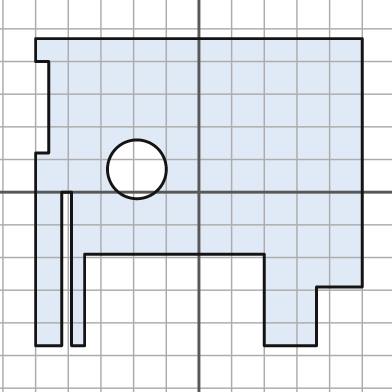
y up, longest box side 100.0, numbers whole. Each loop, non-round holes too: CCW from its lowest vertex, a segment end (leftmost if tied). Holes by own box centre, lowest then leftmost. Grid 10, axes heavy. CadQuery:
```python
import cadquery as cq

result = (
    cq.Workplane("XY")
    .moveTo(-50.0, -47.0)
    .lineTo(-42.0, -47.0)
    .lineTo(-42.0, 0.0)
    .lineTo(-39.0, 0.0)
    .lineTo(-39.0, -47.0)
    .lineTo(-35.0, -47.0)
    .lineTo(-35.0, -19.0)
    .lineTo(20.0, -19.0)
    .lineTo(20.0, -47.0)
    .lineTo(36.0, -47.0)
    .lineTo(36.0, -29.0)
    .lineTo(50.0, -29.0)
    .lineTo(50.0, 47.0)
    .lineTo(-50.0, 47.0)
    .lineTo(-50.0, 40.0)
    .lineTo(-46.0, 40.0)
    .lineTo(-46.0, 12.0)
    .lineTo(-50.0, 12.0)
    .close()
    .moveTo(-19.0, 7.0)
    .circle(9.0)
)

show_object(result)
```